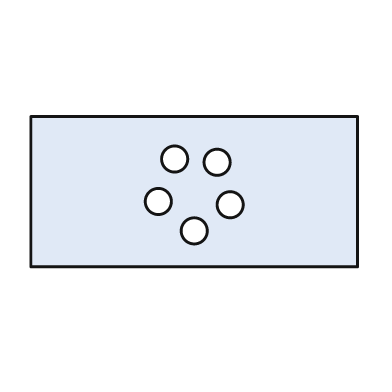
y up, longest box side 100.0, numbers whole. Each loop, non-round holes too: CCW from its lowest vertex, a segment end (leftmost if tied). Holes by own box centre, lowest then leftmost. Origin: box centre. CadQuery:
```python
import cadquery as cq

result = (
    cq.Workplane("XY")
    .moveTo(-50.0, -23.0)
    .lineTo(50.0, -23.0)
    .lineTo(50.0, 23.0)
    .lineTo(-50.0, 23.0)
    .close()
    .moveTo(0.0, -12.0)
    .circle(4.0)
    .moveTo(11.0, -4.0)
    .circle(4.0)
    .moveTo(-11.0, -3.0)
    .circle(4.0)
    .moveTo(7.0, 9.0)
    .circle(4.0)
    .moveTo(-6.0, 10.0)
    .circle(4.0)
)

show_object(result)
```